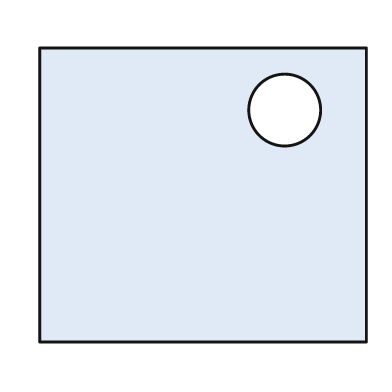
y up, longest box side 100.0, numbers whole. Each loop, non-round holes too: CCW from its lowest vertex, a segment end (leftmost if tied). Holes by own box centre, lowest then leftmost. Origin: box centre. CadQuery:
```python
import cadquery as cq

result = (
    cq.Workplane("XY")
    .moveTo(-50.0, -45.0)
    .lineTo(50.0, -45.0)
    .lineTo(50.0, 45.0)
    .lineTo(-50.0, 45.0)
    .close()
    .moveTo(25.0, 26.0)
    .circle(11.0)
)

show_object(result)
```